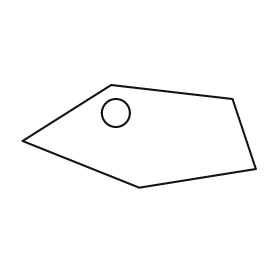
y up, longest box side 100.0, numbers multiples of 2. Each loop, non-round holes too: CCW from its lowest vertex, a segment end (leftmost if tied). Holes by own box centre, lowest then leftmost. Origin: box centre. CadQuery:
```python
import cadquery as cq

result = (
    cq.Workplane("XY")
    .moveTo(0.0, -22.0)
    .lineTo(50.0, -14.0)
    .lineTo(40.0, 16.0)
    .lineTo(-12.0, 22.0)
    .lineTo(-50.0, -2.0)
    .close()
    .moveTo(-10.0, 10.0)
    .circle(6.0)
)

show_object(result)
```